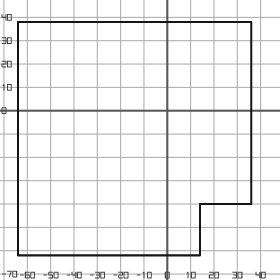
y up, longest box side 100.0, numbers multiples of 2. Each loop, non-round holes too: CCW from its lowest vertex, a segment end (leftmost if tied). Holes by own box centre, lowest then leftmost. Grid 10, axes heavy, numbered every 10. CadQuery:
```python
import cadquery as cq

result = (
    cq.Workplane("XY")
    .moveTo(-64.0, -62.0)
    .lineTo(14.0, -62.0)
    .lineTo(14.0, -40.0)
    .lineTo(36.0, -40.0)
    .lineTo(36.0, 38.0)
    .lineTo(-64.0, 38.0)
    .close()
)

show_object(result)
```